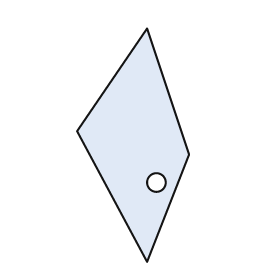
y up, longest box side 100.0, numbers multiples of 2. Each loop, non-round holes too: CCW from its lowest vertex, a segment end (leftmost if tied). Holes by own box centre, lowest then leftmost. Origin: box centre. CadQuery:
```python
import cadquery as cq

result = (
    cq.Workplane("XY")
    .moveTo(6.0, -50.0)
    .lineTo(24.0, -4.0)
    .lineTo(6.0, 50.0)
    .lineTo(-24.0, 6.0)
    .close()
    .moveTo(10.0, -16.0)
    .circle(4.0)
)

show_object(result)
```